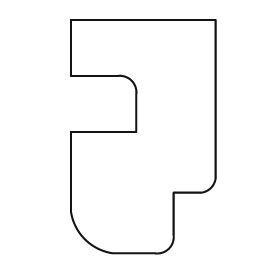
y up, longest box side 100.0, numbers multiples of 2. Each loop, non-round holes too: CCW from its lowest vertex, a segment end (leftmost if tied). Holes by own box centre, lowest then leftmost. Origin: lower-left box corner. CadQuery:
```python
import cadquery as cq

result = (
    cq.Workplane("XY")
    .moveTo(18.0, 0.0)
    .lineTo(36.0, 0.0)
    .threePointArc((42.0, 2.0), (44.0, 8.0))
    .lineTo(44.0, 26.0)
    .lineTo(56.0, 26.0)
    .threePointArc((60.0, 28.0), (62.0, 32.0))
    .lineTo(62.0, 100.0)
    .lineTo(0.0, 100.0)
    .lineTo(0.0, 76.0)
    .lineTo(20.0, 76.0)
    .threePointArc((26.0, 74.0), (28.0, 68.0))
    .lineTo(28.0, 52.0)
    .lineTo(0.0, 52.0)
    .lineTo(0.0, 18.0)
    .threePointArc((6.0, 6.0), (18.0, 0.0))
    .close()
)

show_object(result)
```